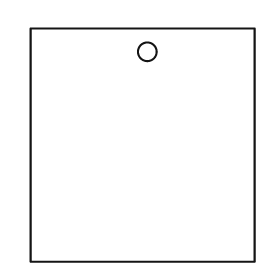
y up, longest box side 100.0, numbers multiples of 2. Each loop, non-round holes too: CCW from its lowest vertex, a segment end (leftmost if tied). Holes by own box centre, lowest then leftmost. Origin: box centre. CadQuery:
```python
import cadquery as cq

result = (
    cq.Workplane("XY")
    .moveTo(-48.0, -50.0)
    .lineTo(48.0, -50.0)
    .lineTo(48.0, 50.0)
    .lineTo(-48.0, 50.0)
    .close()
    .moveTo(2.0, 40.0)
    .circle(4.0)
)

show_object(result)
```